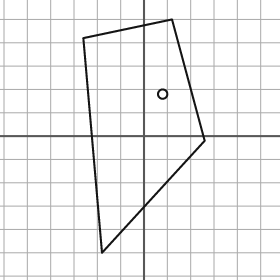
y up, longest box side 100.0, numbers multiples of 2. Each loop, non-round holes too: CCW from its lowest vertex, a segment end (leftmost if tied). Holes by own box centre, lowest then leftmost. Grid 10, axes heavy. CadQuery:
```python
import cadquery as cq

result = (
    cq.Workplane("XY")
    .moveTo(-18.0, -50.0)
    .lineTo(26.0, -2.0)
    .lineTo(12.0, 50.0)
    .lineTo(-26.0, 42.0)
    .close()
    .moveTo(8.0, 18.0)
    .circle(2.0)
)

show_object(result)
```